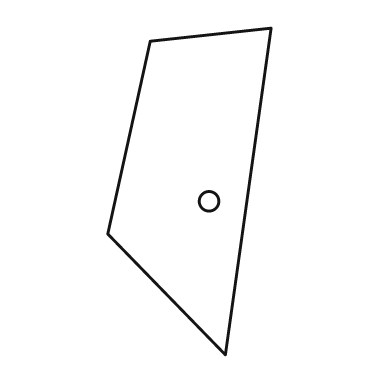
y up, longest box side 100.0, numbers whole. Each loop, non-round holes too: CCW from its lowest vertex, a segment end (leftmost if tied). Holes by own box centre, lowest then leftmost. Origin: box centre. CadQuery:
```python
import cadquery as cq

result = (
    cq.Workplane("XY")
    .moveTo(11.0, -50.0)
    .lineTo(25.0, 50.0)
    .lineTo(-12.0, 46.0)
    .lineTo(-25.0, -13.0)
    .close()
    .moveTo(6.0, -3.0)
    .circle(3.0)
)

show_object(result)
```